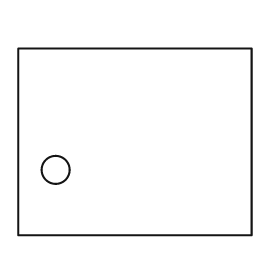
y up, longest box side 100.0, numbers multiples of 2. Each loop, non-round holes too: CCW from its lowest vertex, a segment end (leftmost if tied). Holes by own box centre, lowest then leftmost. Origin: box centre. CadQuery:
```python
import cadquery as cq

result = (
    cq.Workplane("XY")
    .moveTo(-50.0, -40.0)
    .lineTo(50.0, -40.0)
    .lineTo(50.0, 40.0)
    .lineTo(-50.0, 40.0)
    .close()
    .moveTo(-34.0, -12.0)
    .circle(6.0)
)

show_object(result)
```